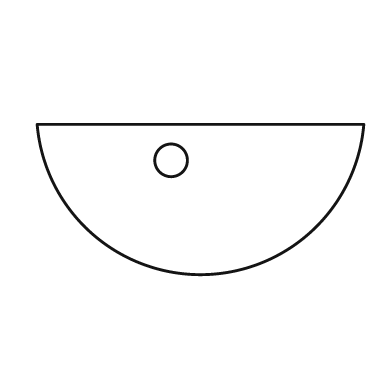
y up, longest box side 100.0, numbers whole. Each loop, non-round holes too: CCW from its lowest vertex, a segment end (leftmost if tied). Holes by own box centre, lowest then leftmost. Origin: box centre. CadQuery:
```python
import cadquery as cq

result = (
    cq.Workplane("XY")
    .moveTo(-50.0, 23.0)
    .threePointArc((0.0, -23.0), (50.0, 23.0))
    .close()
    .moveTo(-9.0, 12.0)
    .circle(5.0)
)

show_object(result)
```